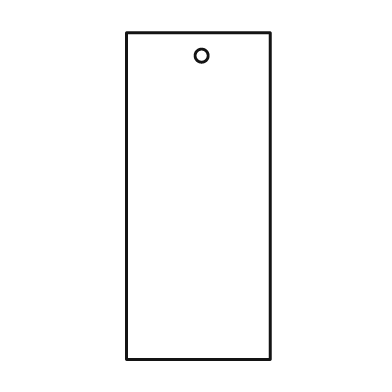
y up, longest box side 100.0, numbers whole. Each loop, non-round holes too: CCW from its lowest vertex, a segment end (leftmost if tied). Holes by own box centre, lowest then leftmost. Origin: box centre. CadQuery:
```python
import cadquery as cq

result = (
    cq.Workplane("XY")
    .moveTo(-22.0, -50.0)
    .lineTo(22.0, -50.0)
    .lineTo(22.0, 50.0)
    .lineTo(-22.0, 50.0)
    .close()
    .moveTo(1.0, 43.0)
    .circle(2.0)
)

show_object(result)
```